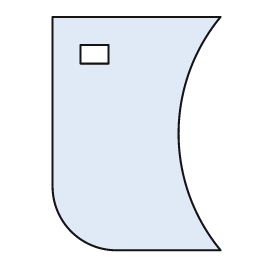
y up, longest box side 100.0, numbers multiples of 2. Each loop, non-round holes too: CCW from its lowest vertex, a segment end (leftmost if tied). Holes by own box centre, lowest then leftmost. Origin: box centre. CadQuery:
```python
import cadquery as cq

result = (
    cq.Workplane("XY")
    .moveTo(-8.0, -50.0)
    .lineTo(36.0, -50.0)
    .threePointArc((18.0, 0.0), (36.0, 50.0))
    .lineTo(-36.0, 50.0)
    .lineTo(-36.0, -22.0)
    .threePointArc((-28.0, -42.0), (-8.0, -50.0))
    .close()
    .moveTo(-24.0, 30.0)
    .lineTo(-12.0, 30.0)
    .lineTo(-12.0, 38.0)
    .lineTo(-24.0, 38.0)
    .close()
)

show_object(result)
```